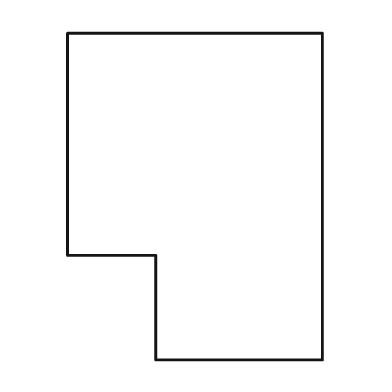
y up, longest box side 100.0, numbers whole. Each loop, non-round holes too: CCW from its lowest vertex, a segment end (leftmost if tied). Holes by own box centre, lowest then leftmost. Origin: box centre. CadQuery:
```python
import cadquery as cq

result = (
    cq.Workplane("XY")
    .moveTo(-12.0, -50.0)
    .lineTo(39.0, -50.0)
    .lineTo(39.0, 50.0)
    .lineTo(-39.0, 50.0)
    .lineTo(-39.0, -18.0)
    .lineTo(-12.0, -18.0)
    .close()
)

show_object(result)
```